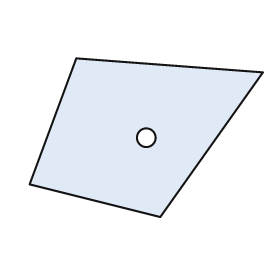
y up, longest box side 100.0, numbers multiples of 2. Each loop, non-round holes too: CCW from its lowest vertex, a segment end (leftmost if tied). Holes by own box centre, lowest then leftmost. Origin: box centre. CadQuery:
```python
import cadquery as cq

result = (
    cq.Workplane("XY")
    .moveTo(6.0, -34.0)
    .lineTo(50.0, 28.0)
    .lineTo(-30.0, 34.0)
    .lineTo(-50.0, -20.0)
    .close()
    .moveTo(0.0, 0.0)
    .circle(4.0)
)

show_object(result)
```